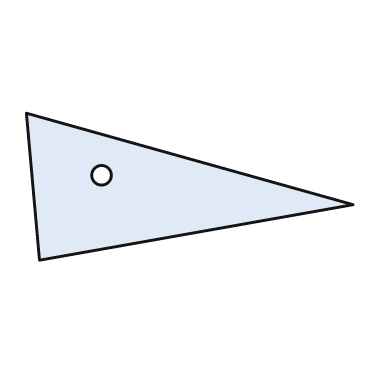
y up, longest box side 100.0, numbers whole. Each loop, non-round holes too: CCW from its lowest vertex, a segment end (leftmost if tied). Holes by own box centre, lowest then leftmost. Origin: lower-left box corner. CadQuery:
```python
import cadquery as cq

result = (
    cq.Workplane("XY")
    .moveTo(4.0, 0.0)
    .lineTo(100.0, 17.0)
    .lineTo(0.0, 45.0)
    .close()
    .moveTo(23.0, 26.0)
    .circle(3.0)
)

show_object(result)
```